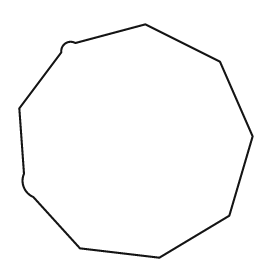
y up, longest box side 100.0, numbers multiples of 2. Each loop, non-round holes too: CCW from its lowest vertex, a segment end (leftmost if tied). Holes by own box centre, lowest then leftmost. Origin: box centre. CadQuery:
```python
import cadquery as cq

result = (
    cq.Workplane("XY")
    .moveTo(10.0, -50.0)
    .lineTo(40.0, -32.0)
    .lineTo(50.0, 2.0)
    .lineTo(36.0, 34.0)
    .lineTo(4.0, 50.0)
    .lineTo(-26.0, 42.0)
    .threePointArc((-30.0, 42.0), (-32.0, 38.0))
    .lineTo(-50.0, 14.0)
    .lineTo(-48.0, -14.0)
    .threePointArc((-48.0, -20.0), (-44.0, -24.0))
    .lineTo(-24.0, -46.0)
    .close()
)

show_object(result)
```